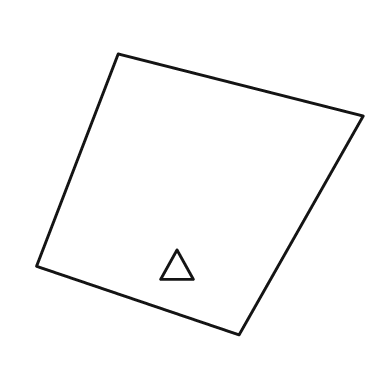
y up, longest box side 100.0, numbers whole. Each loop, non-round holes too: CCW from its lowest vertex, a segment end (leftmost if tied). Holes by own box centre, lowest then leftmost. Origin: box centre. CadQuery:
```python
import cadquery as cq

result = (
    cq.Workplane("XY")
    .moveTo(12.0, -43.0)
    .lineTo(50.0, 24.0)
    .lineTo(-25.0, 43.0)
    .lineTo(-50.0, -22.0)
    .close()
    .moveTo(-12.0, -26.0)
    .lineTo(-2.0, -26.0)
    .lineTo(-7.0, -17.0)
    .close()
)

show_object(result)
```